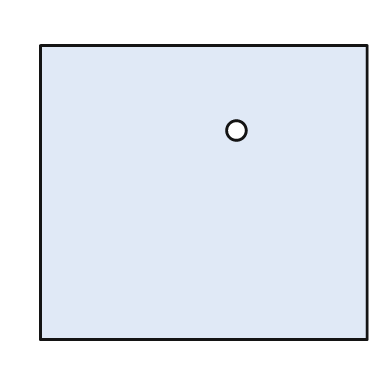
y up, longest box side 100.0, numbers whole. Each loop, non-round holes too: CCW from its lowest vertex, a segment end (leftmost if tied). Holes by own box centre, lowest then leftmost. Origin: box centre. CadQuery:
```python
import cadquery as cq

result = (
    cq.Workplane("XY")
    .moveTo(-50.0, -45.0)
    .lineTo(50.0, -45.0)
    .lineTo(50.0, 45.0)
    .lineTo(-50.0, 45.0)
    .close()
    .moveTo(10.0, 19.0)
    .circle(3.0)
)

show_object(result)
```